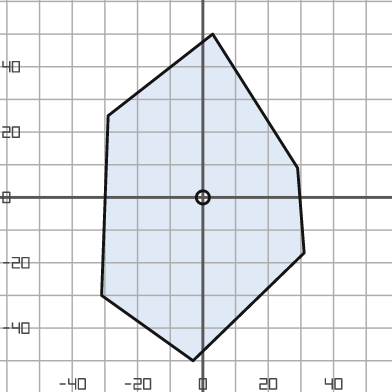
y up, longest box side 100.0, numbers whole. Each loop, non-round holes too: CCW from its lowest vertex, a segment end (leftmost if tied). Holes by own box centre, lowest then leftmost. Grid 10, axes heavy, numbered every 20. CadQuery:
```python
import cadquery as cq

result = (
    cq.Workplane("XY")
    .moveTo(-3.0, -50.0)
    .lineTo(31.0, -17.0)
    .lineTo(29.0, 9.0)
    .lineTo(3.0, 50.0)
    .lineTo(-29.0, 25.0)
    .lineTo(-31.0, -30.0)
    .close()
    .moveTo(0.0, 0.0)
    .circle(2.0)
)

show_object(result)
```